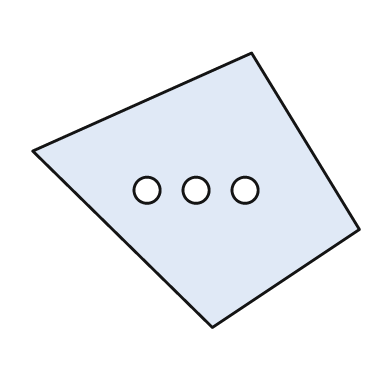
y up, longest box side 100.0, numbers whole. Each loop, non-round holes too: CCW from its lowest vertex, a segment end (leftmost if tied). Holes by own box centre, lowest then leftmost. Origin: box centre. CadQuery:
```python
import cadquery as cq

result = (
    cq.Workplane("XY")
    .moveTo(5.0, -42.0)
    .lineTo(50.0, -12.0)
    .lineTo(17.0, 42.0)
    .lineTo(-50.0, 12.0)
    .close()
    .moveTo(-15.0, 0.0)
    .circle(4.0)
    .moveTo(0.0, 0.0)
    .circle(4.0)
    .moveTo(15.0, 0.0)
    .circle(4.0)
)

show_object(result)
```